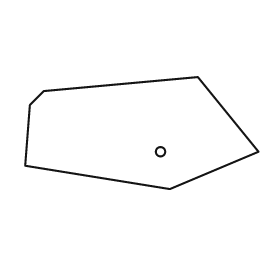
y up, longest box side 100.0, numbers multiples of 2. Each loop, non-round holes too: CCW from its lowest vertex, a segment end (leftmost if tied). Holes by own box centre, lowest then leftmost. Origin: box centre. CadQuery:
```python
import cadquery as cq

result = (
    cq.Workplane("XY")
    .moveTo(12.0, -24.0)
    .lineTo(50.0, -8.0)
    .lineTo(24.0, 24.0)
    .lineTo(-42.0, 18.0)
    .lineTo(-48.0, 12.0)
    .lineTo(-50.0, -14.0)
    .close()
    .moveTo(8.0, -8.0)
    .circle(2.0)
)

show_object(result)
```